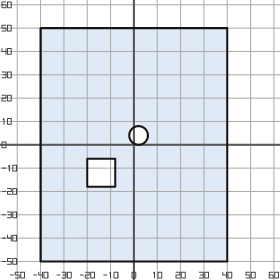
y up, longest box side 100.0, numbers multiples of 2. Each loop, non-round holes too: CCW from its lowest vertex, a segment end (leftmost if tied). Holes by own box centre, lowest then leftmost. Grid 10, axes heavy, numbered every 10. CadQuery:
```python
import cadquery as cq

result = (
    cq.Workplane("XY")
    .moveTo(-40.0, -50.0)
    .lineTo(40.0, -50.0)
    .lineTo(40.0, 50.0)
    .lineTo(-40.0, 50.0)
    .close()
    .moveTo(-20.0, -18.0)
    .lineTo(-8.0, -18.0)
    .lineTo(-8.0, -6.0)
    .lineTo(-20.0, -6.0)
    .close()
    .moveTo(2.0, 4.0)
    .circle(4.0)
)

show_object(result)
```